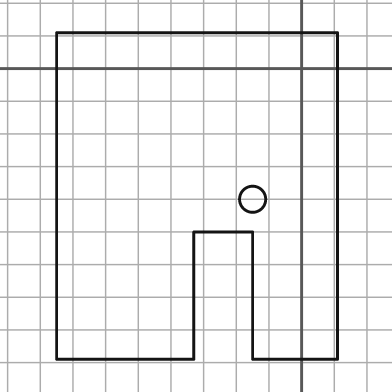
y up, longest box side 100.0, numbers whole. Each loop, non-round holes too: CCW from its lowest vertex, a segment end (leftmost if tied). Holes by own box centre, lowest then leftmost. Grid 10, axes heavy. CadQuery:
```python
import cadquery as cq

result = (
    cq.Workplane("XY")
    .moveTo(-75.0, -89.0)
    .lineTo(-33.0, -89.0)
    .lineTo(-33.0, -50.0)
    .lineTo(-15.0, -50.0)
    .lineTo(-15.0, -89.0)
    .lineTo(11.0, -89.0)
    .lineTo(11.0, 11.0)
    .lineTo(-75.0, 11.0)
    .close()
    .moveTo(-15.0, -40.0)
    .circle(4.0)
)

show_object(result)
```